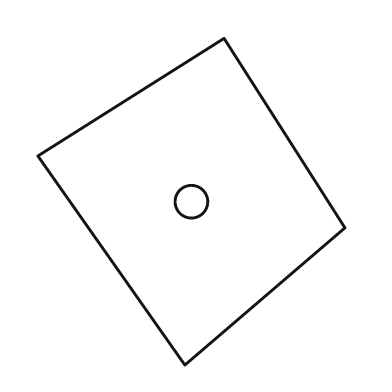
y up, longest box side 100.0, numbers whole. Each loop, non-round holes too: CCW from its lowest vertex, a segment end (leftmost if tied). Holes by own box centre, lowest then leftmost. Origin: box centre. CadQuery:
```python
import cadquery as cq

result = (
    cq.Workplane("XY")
    .moveTo(-2.0, -50.0)
    .lineTo(47.0, -8.0)
    .lineTo(10.0, 50.0)
    .lineTo(-47.0, 14.0)
    .close()
    .moveTo(0.0, 0.0)
    .circle(5.0)
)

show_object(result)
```